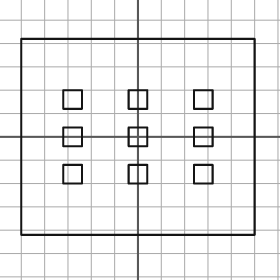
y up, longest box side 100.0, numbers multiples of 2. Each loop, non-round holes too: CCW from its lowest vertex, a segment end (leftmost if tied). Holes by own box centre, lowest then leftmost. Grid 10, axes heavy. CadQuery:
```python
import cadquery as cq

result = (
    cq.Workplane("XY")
    .moveTo(-50.0, -42.0)
    .lineTo(50.0, -42.0)
    .lineTo(50.0, 42.0)
    .lineTo(-50.0, 42.0)
    .close()
    .moveTo(-32.0, -20.0)
    .lineTo(-24.0, -20.0)
    .lineTo(-24.0, -12.0)
    .lineTo(-32.0, -12.0)
    .close()
    .moveTo(-4.0, -20.0)
    .lineTo(4.0, -20.0)
    .lineTo(4.0, -12.0)
    .lineTo(-4.0, -12.0)
    .close()
    .moveTo(24.0, -20.0)
    .lineTo(32.0, -20.0)
    .lineTo(32.0, -12.0)
    .lineTo(24.0, -12.0)
    .close()
    .moveTo(-32.0, -4.0)
    .lineTo(-24.0, -4.0)
    .lineTo(-24.0, 4.0)
    .lineTo(-32.0, 4.0)
    .close()
    .moveTo(-4.0, -4.0)
    .lineTo(4.0, -4.0)
    .lineTo(4.0, 4.0)
    .lineTo(-4.0, 4.0)
    .close()
    .moveTo(24.0, -4.0)
    .lineTo(32.0, -4.0)
    .lineTo(32.0, 4.0)
    .lineTo(24.0, 4.0)
    .close()
    .moveTo(-32.0, 12.0)
    .lineTo(-24.0, 12.0)
    .lineTo(-24.0, 20.0)
    .lineTo(-32.0, 20.0)
    .close()
    .moveTo(-4.0, 12.0)
    .lineTo(4.0, 12.0)
    .lineTo(4.0, 20.0)
    .lineTo(-4.0, 20.0)
    .close()
    .moveTo(24.0, 12.0)
    .lineTo(32.0, 12.0)
    .lineTo(32.0, 20.0)
    .lineTo(24.0, 20.0)
    .close()
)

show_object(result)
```